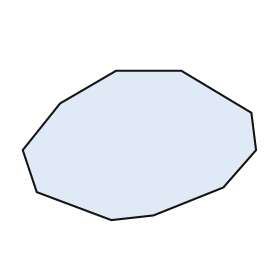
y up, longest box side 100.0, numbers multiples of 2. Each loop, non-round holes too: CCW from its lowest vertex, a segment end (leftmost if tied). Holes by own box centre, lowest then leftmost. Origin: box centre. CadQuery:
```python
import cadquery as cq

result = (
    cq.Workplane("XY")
    .moveTo(-12.0, -32.0)
    .lineTo(6.0, -30.0)
    .lineTo(36.0, -18.0)
    .lineTo(50.0, -2.0)
    .lineTo(48.0, 14.0)
    .lineTo(18.0, 32.0)
    .lineTo(-10.0, 32.0)
    .lineTo(-34.0, 18.0)
    .lineTo(-50.0, -2.0)
    .lineTo(-44.0, -20.0)
    .close()
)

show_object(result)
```